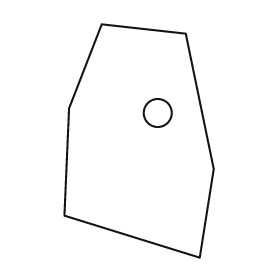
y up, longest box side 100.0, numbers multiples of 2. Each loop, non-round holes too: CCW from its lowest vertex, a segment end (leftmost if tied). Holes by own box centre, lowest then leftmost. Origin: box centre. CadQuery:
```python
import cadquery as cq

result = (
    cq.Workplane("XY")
    .moveTo(26.0, -50.0)
    .lineTo(32.0, -12.0)
    .lineTo(20.0, 46.0)
    .lineTo(-16.0, 50.0)
    .lineTo(-30.0, 14.0)
    .lineTo(-32.0, -32.0)
    .close()
    .moveTo(8.0, 12.0)
    .circle(6.0)
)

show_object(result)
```